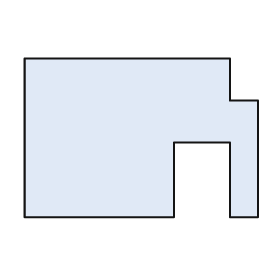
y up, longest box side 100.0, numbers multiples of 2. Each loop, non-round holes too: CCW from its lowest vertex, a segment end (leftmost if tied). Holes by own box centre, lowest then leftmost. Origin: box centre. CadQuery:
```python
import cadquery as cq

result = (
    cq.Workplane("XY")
    .moveTo(-50.0, -34.0)
    .lineTo(14.0, -34.0)
    .lineTo(14.0, -2.0)
    .lineTo(38.0, -2.0)
    .lineTo(38.0, -34.0)
    .lineTo(50.0, -34.0)
    .lineTo(50.0, 16.0)
    .lineTo(38.0, 16.0)
    .lineTo(38.0, 34.0)
    .lineTo(-50.0, 34.0)
    .close()
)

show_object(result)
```